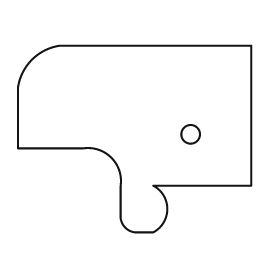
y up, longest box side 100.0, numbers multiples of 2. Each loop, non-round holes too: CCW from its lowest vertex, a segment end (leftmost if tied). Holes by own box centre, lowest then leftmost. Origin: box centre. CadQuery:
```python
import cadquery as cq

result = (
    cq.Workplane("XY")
    .moveTo(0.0, -40.0)
    .lineTo(8.0, -40.0)
    .threePointArc((14.0, -30.0), (8.0, -20.0))
    .lineTo(50.0, -20.0)
    .lineTo(50.0, 40.0)
    .lineTo(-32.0, 40.0)
    .threePointArc((-44.0, 34.0), (-50.0, 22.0))
    .lineTo(-50.0, -4.0)
    .lineTo(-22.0, -4.0)
    .threePointArc((-10.0, -8.0), (-6.0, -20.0))
    .lineTo(-6.0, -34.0)
    .threePointArc((-4.0, -38.0), (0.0, -40.0))
    .close()
    .moveTo(24.0, 2.0)
    .circle(4.0)
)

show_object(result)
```